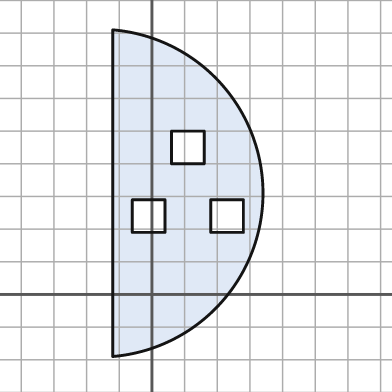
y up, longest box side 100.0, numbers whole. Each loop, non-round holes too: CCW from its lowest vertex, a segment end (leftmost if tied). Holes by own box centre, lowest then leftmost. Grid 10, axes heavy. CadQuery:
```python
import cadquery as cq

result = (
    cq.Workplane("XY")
    .moveTo(-12.0, -19.0)
    .threePointArc((34.0, 31.0), (-12.0, 81.0))
    .close()
    .moveTo(-6.0, 19.0)
    .lineTo(4.0, 19.0)
    .lineTo(4.0, 29.0)
    .lineTo(-6.0, 29.0)
    .close()
    .moveTo(18.0, 19.0)
    .lineTo(28.0, 19.0)
    .lineTo(28.0, 29.0)
    .lineTo(18.0, 29.0)
    .close()
    .moveTo(6.0, 40.0)
    .lineTo(16.0, 40.0)
    .lineTo(16.0, 50.0)
    .lineTo(6.0, 50.0)
    .close()
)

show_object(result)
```